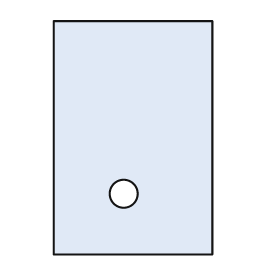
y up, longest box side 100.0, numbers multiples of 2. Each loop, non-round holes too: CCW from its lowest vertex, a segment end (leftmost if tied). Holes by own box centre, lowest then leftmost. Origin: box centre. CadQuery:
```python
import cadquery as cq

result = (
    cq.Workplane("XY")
    .moveTo(-34.0, -50.0)
    .lineTo(34.0, -50.0)
    .lineTo(34.0, 50.0)
    .lineTo(-34.0, 50.0)
    .close()
    .moveTo(-4.0, -24.0)
    .circle(6.0)
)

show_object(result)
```